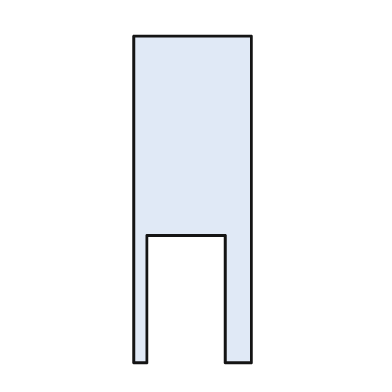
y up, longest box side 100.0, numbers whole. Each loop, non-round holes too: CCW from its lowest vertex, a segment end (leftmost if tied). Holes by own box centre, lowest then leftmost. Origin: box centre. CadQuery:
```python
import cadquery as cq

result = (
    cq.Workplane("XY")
    .moveTo(-18.0, -50.0)
    .lineTo(-14.0, -50.0)
    .lineTo(-14.0, -11.0)
    .lineTo(10.0, -11.0)
    .lineTo(10.0, -50.0)
    .lineTo(18.0, -50.0)
    .lineTo(18.0, 50.0)
    .lineTo(-18.0, 50.0)
    .close()
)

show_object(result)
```